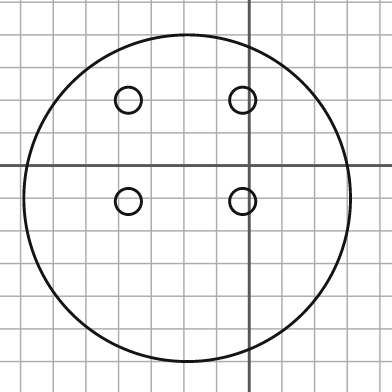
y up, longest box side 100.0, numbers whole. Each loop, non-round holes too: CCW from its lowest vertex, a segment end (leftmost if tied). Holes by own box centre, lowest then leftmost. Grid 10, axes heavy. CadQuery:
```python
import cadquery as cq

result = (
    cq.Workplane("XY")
    .moveTo(-19.0, -10.0)
    .circle(50.0)
    .moveTo(-37.0, -11.0)
    .circle(4.0)
    .moveTo(-2.0, -11.0)
    .circle(4.0)
    .moveTo(-37.0, 20.0)
    .circle(4.0)
    .moveTo(-2.0, 20.0)
    .circle(4.0)
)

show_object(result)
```